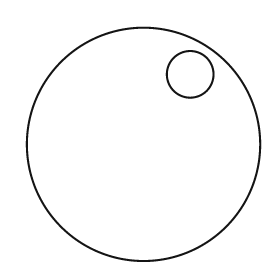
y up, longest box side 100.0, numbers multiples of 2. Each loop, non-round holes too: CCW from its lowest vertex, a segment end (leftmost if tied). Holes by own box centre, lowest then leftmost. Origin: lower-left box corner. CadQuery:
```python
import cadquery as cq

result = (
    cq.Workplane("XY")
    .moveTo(50.0, 50.0)
    .circle(50.0)
    .moveTo(70.0, 80.0)
    .circle(10.0)
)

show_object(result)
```